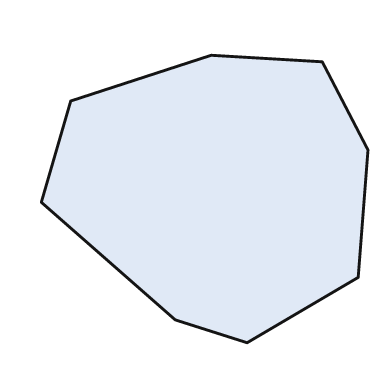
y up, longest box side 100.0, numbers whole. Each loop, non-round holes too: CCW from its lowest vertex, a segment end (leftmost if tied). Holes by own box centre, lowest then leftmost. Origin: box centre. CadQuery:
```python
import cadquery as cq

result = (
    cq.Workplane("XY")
    .moveTo(13.0, -44.0)
    .lineTo(47.0, -24.0)
    .lineTo(50.0, 15.0)
    .lineTo(36.0, 42.0)
    .lineTo(2.0, 44.0)
    .lineTo(-41.0, 30.0)
    .lineTo(-50.0, -1.0)
    .lineTo(-9.0, -37.0)
    .close()
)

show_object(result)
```